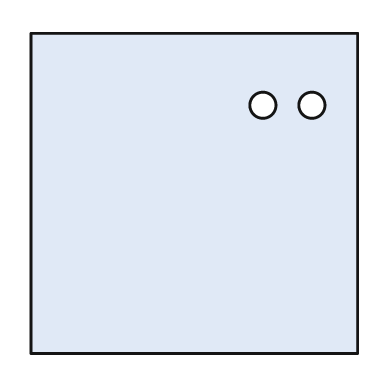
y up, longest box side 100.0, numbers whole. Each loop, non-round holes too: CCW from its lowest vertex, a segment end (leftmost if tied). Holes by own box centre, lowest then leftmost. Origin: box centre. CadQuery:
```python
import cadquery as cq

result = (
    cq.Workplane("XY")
    .moveTo(-50.0, -49.0)
    .lineTo(50.0, -49.0)
    .lineTo(50.0, 49.0)
    .lineTo(-50.0, 49.0)
    .close()
    .moveTo(21.0, 27.0)
    .circle(4.0)
    .moveTo(36.0, 27.0)
    .circle(4.0)
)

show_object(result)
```